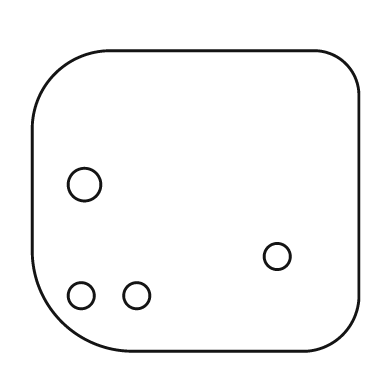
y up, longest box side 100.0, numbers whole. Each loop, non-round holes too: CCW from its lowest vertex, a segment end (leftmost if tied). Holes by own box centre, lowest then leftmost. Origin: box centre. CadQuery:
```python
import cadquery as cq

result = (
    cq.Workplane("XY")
    .moveTo(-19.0, -46.0)
    .lineTo(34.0, -46.0)
    .threePointArc((45.0, -41.0), (50.0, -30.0))
    .lineTo(50.0, 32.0)
    .threePointArc((46.0, 42.0), (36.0, 46.0))
    .lineTo(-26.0, 46.0)
    .threePointArc((-43.0, 39.0), (-50.0, 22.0))
    .lineTo(-50.0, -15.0)
    .threePointArc((-41.0, -37.0), (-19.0, -46.0))
    .close()
    .moveTo(-35.0, -29.0)
    .circle(4.0)
    .moveTo(-18.0, -29.0)
    .circle(4.0)
    .moveTo(25.0, -17.0)
    .circle(4.0)
    .moveTo(-34.0, 5.0)
    .circle(5.0)
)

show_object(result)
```